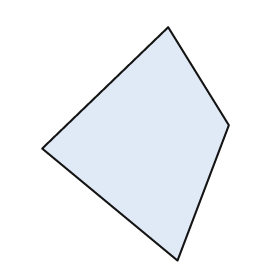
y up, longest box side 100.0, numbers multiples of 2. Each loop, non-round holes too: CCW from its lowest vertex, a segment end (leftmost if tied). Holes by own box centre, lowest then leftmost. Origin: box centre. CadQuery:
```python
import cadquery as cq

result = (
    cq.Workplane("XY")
    .moveTo(18.0, -50.0)
    .lineTo(40.0, 8.0)
    .lineTo(14.0, 50.0)
    .lineTo(-40.0, -2.0)
    .close()
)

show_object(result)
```